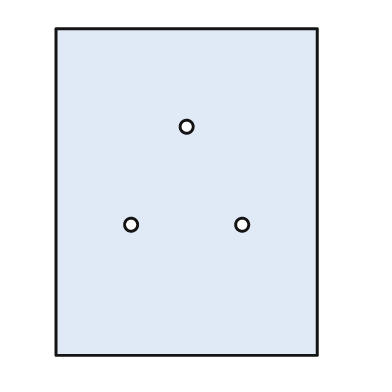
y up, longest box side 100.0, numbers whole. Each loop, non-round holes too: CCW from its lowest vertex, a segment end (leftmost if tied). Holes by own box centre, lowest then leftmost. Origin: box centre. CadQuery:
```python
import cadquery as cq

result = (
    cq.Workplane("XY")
    .moveTo(-40.0, -50.0)
    .lineTo(40.0, -50.0)
    .lineTo(40.0, 50.0)
    .lineTo(-40.0, 50.0)
    .close()
    .moveTo(-17.0, -10.0)
    .circle(2.0)
    .moveTo(17.0, -10.0)
    .circle(2.0)
    .moveTo(0.0, 20.0)
    .circle(2.0)
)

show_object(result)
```